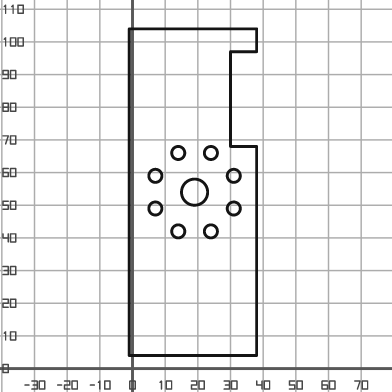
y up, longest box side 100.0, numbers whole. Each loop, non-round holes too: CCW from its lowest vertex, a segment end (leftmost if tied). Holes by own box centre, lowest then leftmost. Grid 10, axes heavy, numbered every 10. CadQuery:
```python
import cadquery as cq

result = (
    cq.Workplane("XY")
    .moveTo(-1.0, 4.0)
    .lineTo(38.0, 4.0)
    .lineTo(38.0, 68.0)
    .lineTo(30.0, 68.0)
    .lineTo(30.0, 97.0)
    .lineTo(38.0, 97.0)
    .lineTo(38.0, 104.0)
    .lineTo(-1.0, 104.0)
    .close()
    .moveTo(14.0, 42.0)
    .circle(2.0)
    .moveTo(24.0, 42.0)
    .circle(2.0)
    .moveTo(7.0, 49.0)
    .circle(2.0)
    .moveTo(31.0, 49.0)
    .circle(2.0)
    .moveTo(19.0, 54.0)
    .circle(4.0)
    .moveTo(7.0, 59.0)
    .circle(2.0)
    .moveTo(31.0, 59.0)
    .circle(2.0)
    .moveTo(14.0, 66.0)
    .circle(2.0)
    .moveTo(24.0, 66.0)
    .circle(2.0)
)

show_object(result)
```